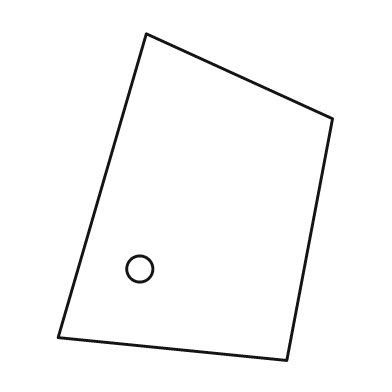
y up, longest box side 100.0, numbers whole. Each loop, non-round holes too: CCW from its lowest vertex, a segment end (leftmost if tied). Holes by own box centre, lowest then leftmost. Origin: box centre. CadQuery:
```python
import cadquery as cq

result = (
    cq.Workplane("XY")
    .moveTo(28.0, -50.0)
    .lineTo(42.0, 24.0)
    .lineTo(-15.0, 50.0)
    .lineTo(-42.0, -43.0)
    .close()
    .moveTo(-17.0, -22.0)
    .circle(4.0)
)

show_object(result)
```